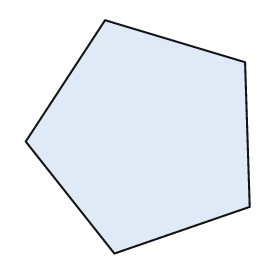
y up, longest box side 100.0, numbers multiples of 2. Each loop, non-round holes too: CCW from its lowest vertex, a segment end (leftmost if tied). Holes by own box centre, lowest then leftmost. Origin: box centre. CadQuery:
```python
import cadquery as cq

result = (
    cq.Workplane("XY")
    .moveTo(-10.0, -50.0)
    .lineTo(48.0, -30.0)
    .lineTo(46.0, 32.0)
    .lineTo(-14.0, 50.0)
    .lineTo(-48.0, -2.0)
    .close()
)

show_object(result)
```